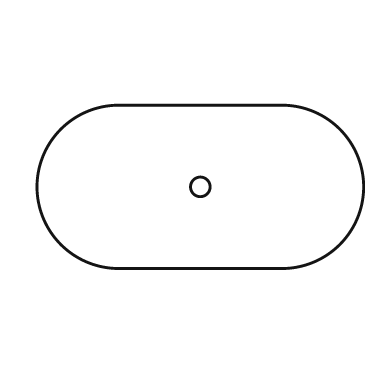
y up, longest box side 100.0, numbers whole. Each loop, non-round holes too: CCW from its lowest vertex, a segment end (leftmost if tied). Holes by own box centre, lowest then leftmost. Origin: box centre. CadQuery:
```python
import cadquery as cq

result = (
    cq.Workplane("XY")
    .moveTo(-25.0, -25.0)
    .lineTo(25.0, -25.0)
    .threePointArc((50.0, 0.0), (25.0, 25.0))
    .lineTo(-25.0, 25.0)
    .threePointArc((-50.0, 0.0), (-25.0, -25.0))
    .close()
    .moveTo(0.0, 0.0)
    .circle(3.0)
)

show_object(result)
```